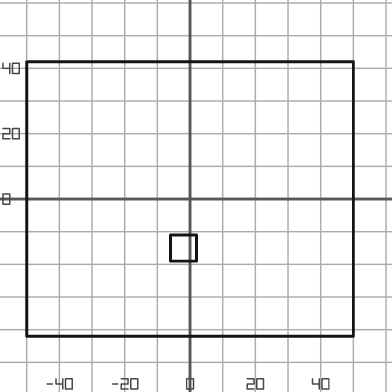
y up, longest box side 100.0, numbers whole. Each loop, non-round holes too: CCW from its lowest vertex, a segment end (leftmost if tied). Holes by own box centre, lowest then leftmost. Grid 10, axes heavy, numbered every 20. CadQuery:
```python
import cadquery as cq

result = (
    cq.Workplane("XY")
    .moveTo(-50.0, -42.0)
    .lineTo(50.0, -42.0)
    .lineTo(50.0, 42.0)
    .lineTo(-50.0, 42.0)
    .close()
    .moveTo(-6.0, -19.0)
    .lineTo(2.0, -19.0)
    .lineTo(2.0, -11.0)
    .lineTo(-6.0, -11.0)
    .close()
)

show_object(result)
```